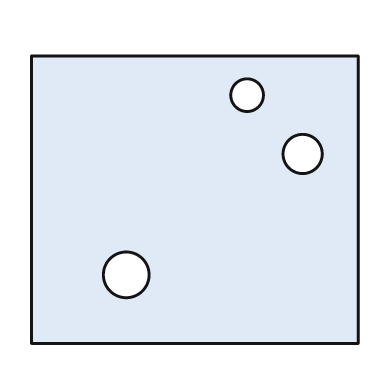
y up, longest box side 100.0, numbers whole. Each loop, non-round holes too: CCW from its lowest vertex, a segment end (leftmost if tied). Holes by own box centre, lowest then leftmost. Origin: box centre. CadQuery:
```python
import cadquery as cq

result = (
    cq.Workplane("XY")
    .moveTo(-50.0, -44.0)
    .lineTo(50.0, -44.0)
    .lineTo(50.0, 44.0)
    .lineTo(-50.0, 44.0)
    .close()
    .moveTo(-21.0, -23.0)
    .circle(7.0)
    .moveTo(33.0, 14.0)
    .circle(6.0)
    .moveTo(16.0, 32.0)
    .circle(5.0)
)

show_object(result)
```